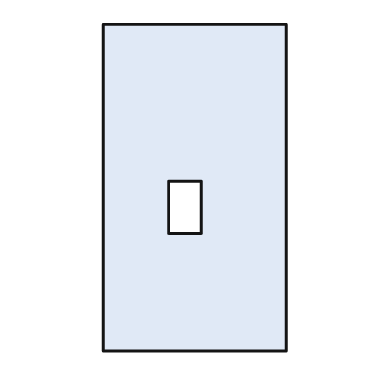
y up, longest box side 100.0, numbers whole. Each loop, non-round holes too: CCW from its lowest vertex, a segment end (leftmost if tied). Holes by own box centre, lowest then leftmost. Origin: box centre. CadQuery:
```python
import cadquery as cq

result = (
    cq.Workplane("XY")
    .moveTo(-28.0, -50.0)
    .lineTo(28.0, -50.0)
    .lineTo(28.0, 50.0)
    .lineTo(-28.0, 50.0)
    .close()
    .moveTo(-8.0, -14.0)
    .lineTo(2.0, -14.0)
    .lineTo(2.0, 2.0)
    .lineTo(-8.0, 2.0)
    .close()
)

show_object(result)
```